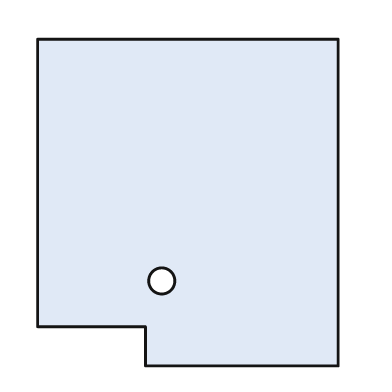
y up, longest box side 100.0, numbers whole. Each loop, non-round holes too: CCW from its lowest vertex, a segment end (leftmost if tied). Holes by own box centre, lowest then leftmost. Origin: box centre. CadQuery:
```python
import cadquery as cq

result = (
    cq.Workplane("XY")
    .moveTo(-13.0, -50.0)
    .lineTo(46.0, -50.0)
    .lineTo(46.0, 50.0)
    .lineTo(-46.0, 50.0)
    .lineTo(-46.0, -38.0)
    .lineTo(-13.0, -38.0)
    .close()
    .moveTo(-8.0, -24.0)
    .circle(4.0)
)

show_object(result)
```